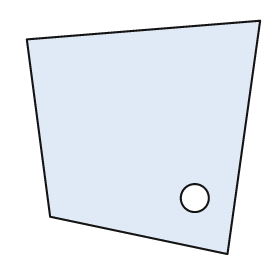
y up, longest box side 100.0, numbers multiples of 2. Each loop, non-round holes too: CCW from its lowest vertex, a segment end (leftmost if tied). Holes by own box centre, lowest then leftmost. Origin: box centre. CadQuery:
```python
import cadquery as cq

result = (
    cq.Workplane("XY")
    .moveTo(36.0, -50.0)
    .lineTo(50.0, 50.0)
    .lineTo(-50.0, 42.0)
    .lineTo(-40.0, -34.0)
    .close()
    .moveTo(22.0, -26.0)
    .circle(6.0)
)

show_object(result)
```